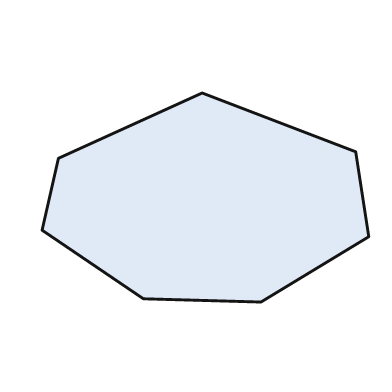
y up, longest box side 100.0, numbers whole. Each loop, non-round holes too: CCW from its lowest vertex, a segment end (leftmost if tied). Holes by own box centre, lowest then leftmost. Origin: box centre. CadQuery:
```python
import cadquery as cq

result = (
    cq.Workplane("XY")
    .moveTo(17.0, -32.0)
    .lineTo(50.0, -12.0)
    .lineTo(46.0, 14.0)
    .lineTo(-1.0, 32.0)
    .lineTo(-45.0, 12.0)
    .lineTo(-50.0, -10.0)
    .lineTo(-19.0, -31.0)
    .close()
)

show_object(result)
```